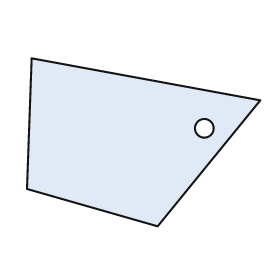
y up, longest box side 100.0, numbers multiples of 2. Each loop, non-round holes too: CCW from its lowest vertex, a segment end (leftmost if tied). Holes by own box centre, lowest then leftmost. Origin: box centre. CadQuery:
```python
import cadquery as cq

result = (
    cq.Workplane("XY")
    .moveTo(6.0, -36.0)
    .lineTo(50.0, 18.0)
    .lineTo(-48.0, 36.0)
    .lineTo(-50.0, -20.0)
    .close()
    .moveTo(26.0, 6.0)
    .circle(4.0)
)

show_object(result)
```